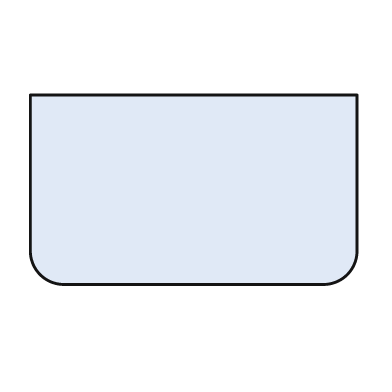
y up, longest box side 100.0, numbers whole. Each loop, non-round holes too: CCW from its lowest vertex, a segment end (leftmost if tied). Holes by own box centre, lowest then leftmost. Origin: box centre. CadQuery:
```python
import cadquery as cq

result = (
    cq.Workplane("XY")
    .moveTo(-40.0, -29.0)
    .lineTo(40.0, -29.0)
    .threePointArc((47.0, -26.0), (50.0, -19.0))
    .lineTo(50.0, 29.0)
    .lineTo(-50.0, 29.0)
    .lineTo(-50.0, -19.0)
    .threePointArc((-47.0, -26.0), (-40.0, -29.0))
    .close()
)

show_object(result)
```